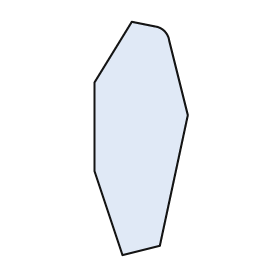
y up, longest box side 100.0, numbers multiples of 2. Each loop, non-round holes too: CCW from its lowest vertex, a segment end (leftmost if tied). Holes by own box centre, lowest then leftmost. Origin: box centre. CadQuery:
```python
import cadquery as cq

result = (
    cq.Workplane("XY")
    .moveTo(-8.0, -50.0)
    .lineTo(8.0, -46.0)
    .lineTo(20.0, 10.0)
    .lineTo(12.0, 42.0)
    .threePointArc((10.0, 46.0), (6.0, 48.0))
    .lineTo(-4.0, 50.0)
    .lineTo(-20.0, 24.0)
    .lineTo(-20.0, -14.0)
    .close()
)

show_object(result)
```